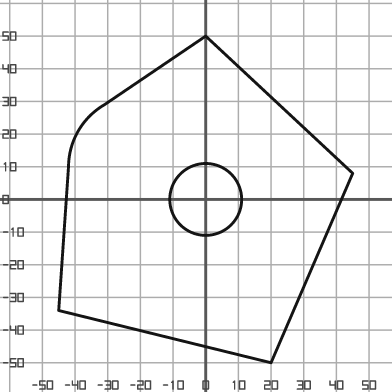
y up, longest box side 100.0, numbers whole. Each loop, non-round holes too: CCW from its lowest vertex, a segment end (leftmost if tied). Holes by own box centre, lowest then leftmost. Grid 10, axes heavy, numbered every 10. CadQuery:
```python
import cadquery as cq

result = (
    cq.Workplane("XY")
    .moveTo(20.0, -50.0)
    .lineTo(45.0, 8.0)
    .lineTo(0.0, 50.0)
    .lineTo(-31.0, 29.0)
    .threePointArc((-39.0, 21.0), (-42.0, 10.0))
    .lineTo(-45.0, -34.0)
    .close()
    .moveTo(0.0, 0.0)
    .circle(11.0)
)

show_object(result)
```